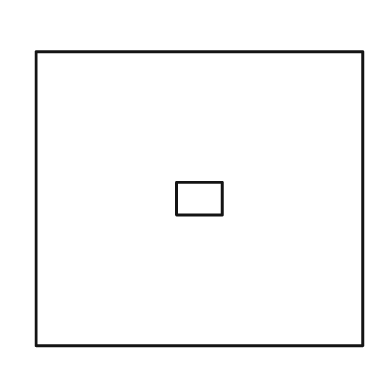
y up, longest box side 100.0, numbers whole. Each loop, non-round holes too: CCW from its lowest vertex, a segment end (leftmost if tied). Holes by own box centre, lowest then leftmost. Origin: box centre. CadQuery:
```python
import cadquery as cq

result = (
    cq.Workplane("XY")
    .moveTo(-50.0, -45.0)
    .lineTo(50.0, -45.0)
    .lineTo(50.0, 45.0)
    .lineTo(-50.0, 45.0)
    .close()
    .moveTo(-7.0, -5.0)
    .lineTo(7.0, -5.0)
    .lineTo(7.0, 5.0)
    .lineTo(-7.0, 5.0)
    .close()
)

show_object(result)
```